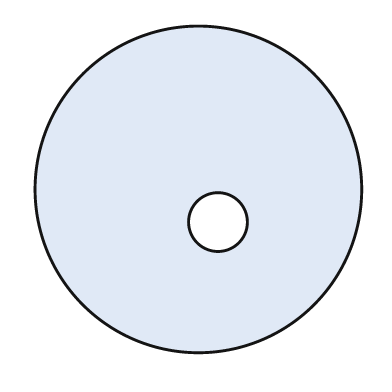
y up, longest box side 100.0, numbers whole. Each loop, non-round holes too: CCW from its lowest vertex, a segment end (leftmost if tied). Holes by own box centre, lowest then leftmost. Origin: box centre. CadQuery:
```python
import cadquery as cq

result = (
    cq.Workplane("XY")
    .moveTo(0.0, 0.0)
    .circle(50.0)
    .moveTo(6.0, -10.0)
    .circle(9.0)
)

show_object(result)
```